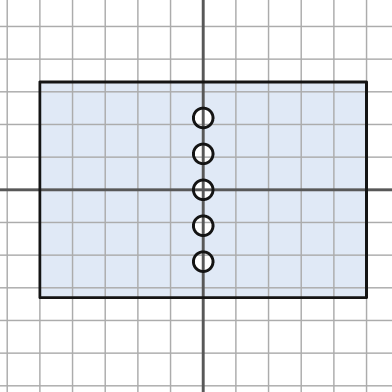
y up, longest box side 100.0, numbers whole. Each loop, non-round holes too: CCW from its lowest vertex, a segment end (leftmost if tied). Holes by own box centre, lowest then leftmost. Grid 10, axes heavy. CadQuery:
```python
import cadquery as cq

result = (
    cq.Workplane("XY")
    .moveTo(-50.0, -33.0)
    .lineTo(50.0, -33.0)
    .lineTo(50.0, 33.0)
    .lineTo(-50.0, 33.0)
    .close()
    .moveTo(0.0, -22.0)
    .circle(3.0)
    .moveTo(0.0, -11.0)
    .circle(3.0)
    .moveTo(0.0, 0.0)
    .circle(3.0)
    .moveTo(0.0, 11.0)
    .circle(3.0)
    .moveTo(0.0, 22.0)
    .circle(3.0)
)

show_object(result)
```